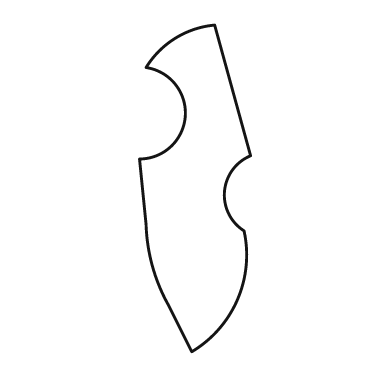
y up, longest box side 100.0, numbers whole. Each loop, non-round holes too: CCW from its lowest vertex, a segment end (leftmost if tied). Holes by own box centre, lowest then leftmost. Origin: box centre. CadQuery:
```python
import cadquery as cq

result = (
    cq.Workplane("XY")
    .moveTo(-1.0, -50.0)
    .threePointArc((13.0, -34.0), (15.0, -13.0))
    .threePointArc((9.0, -1.0), (17.0, 10.0))
    .lineTo(6.0, 50.0)
    .threePointArc((-6.0, 46.0), (-15.0, 37.0))
    .threePointArc((-3.0, 22.0), (-17.0, 9.0))
    .lineTo(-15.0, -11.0)
    .threePointArc((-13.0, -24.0), (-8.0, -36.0))
    .close()
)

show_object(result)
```